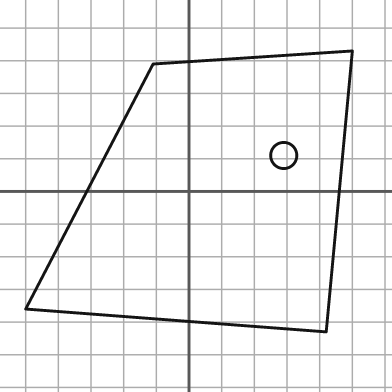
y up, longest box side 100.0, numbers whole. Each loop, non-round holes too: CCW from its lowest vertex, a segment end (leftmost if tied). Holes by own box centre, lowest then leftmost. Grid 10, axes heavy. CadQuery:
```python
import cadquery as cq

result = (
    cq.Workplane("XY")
    .moveTo(42.0, -43.0)
    .lineTo(50.0, 43.0)
    .lineTo(-11.0, 39.0)
    .lineTo(-50.0, -36.0)
    .close()
    .moveTo(29.0, 11.0)
    .circle(4.0)
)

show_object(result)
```